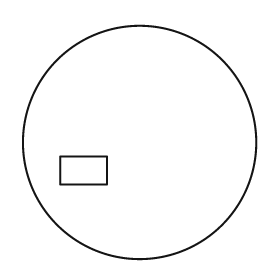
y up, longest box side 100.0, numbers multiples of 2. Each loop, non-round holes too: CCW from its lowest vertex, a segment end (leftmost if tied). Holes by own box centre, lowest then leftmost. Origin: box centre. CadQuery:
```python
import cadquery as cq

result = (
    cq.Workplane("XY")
    .moveTo(0.0, 0.0)
    .circle(50.0)
    .moveTo(-34.0, -18.0)
    .lineTo(-14.0, -18.0)
    .lineTo(-14.0, -6.0)
    .lineTo(-34.0, -6.0)
    .close()
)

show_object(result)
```